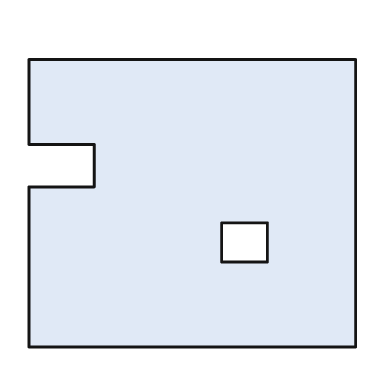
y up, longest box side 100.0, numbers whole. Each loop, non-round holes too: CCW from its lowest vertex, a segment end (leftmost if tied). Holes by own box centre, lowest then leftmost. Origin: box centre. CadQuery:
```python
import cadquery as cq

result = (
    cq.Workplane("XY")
    .moveTo(-50.0, -44.0)
    .lineTo(50.0, -44.0)
    .lineTo(50.0, 44.0)
    .lineTo(-50.0, 44.0)
    .lineTo(-50.0, 18.0)
    .lineTo(-30.0, 18.0)
    .lineTo(-30.0, 5.0)
    .lineTo(-50.0, 5.0)
    .close()
    .moveTo(9.0, -18.0)
    .lineTo(23.0, -18.0)
    .lineTo(23.0, -6.0)
    .lineTo(9.0, -6.0)
    .close()
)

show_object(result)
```